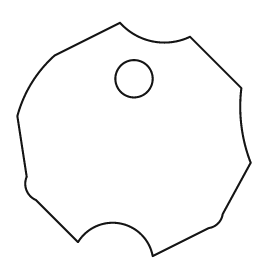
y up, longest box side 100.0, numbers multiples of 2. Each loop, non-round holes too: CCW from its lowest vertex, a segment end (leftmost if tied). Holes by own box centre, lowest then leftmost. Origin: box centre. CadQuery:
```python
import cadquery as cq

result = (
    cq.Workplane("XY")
    .moveTo(8.0, -50.0)
    .lineTo(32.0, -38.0)
    .threePointArc((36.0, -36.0), (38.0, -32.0))
    .lineTo(50.0, -10.0)
    .threePointArc((46.0, 6.0), (46.0, 22.0))
    .lineTo(24.0, 44.0)
    .threePointArc((8.0, 42.0), (-6.0, 50.0))
    .lineTo(-34.0, 36.0)
    .threePointArc((-44.0, 24.0), (-50.0, 10.0))
    .lineTo(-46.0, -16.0)
    .threePointArc((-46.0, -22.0), (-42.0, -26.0))
    .lineTo(-24.0, -44.0)
    .threePointArc((-6.0, -36.0), (8.0, -50.0))
    .close()
    .moveTo(0.0, 26.0)
    .circle(8.0)
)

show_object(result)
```